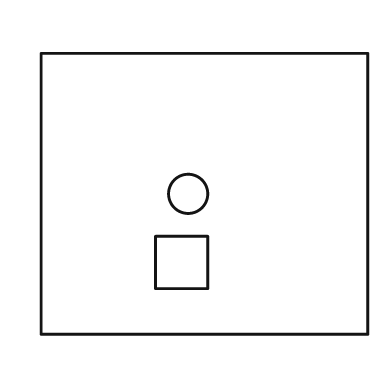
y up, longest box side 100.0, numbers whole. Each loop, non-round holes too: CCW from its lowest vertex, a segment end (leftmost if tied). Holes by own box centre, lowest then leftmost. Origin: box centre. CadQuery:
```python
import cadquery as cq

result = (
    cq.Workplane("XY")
    .moveTo(-50.0, -43.0)
    .lineTo(50.0, -43.0)
    .lineTo(50.0, 43.0)
    .lineTo(-50.0, 43.0)
    .close()
    .moveTo(-15.0, -29.0)
    .lineTo(1.0, -29.0)
    .lineTo(1.0, -13.0)
    .lineTo(-15.0, -13.0)
    .close()
    .moveTo(-5.0, 0.0)
    .circle(6.0)
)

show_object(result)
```